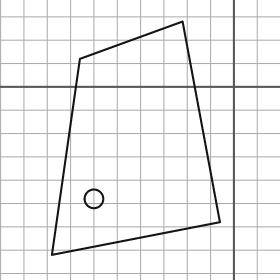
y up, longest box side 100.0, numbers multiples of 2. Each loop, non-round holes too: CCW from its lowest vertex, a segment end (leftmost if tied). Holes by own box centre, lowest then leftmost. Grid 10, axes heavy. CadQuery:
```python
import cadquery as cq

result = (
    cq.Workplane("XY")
    .moveTo(-78.0, -72.0)
    .lineTo(-6.0, -58.0)
    .lineTo(-22.0, 28.0)
    .lineTo(-66.0, 12.0)
    .close()
    .moveTo(-60.0, -48.0)
    .circle(4.0)
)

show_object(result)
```